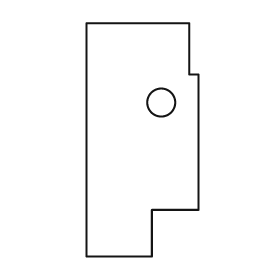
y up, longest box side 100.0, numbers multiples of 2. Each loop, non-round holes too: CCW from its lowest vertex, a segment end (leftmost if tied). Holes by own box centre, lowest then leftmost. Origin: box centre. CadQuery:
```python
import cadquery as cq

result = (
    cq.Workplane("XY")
    .moveTo(-24.0, -50.0)
    .lineTo(4.0, -50.0)
    .lineTo(4.0, -30.0)
    .lineTo(24.0, -30.0)
    .lineTo(24.0, 28.0)
    .lineTo(20.0, 28.0)
    .lineTo(20.0, 50.0)
    .lineTo(-24.0, 50.0)
    .close()
    .moveTo(8.0, 16.0)
    .circle(6.0)
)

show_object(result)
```